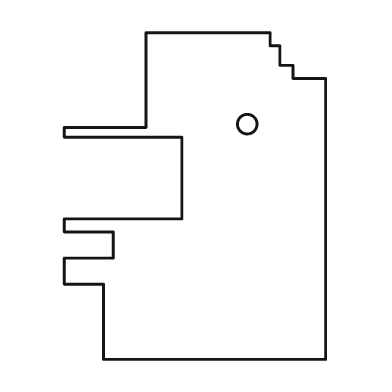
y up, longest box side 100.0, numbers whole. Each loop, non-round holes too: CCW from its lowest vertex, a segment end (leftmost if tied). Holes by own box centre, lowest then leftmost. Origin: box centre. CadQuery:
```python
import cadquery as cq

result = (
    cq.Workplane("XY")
    .moveTo(-28.0, -50.0)
    .lineTo(40.0, -50.0)
    .lineTo(40.0, 36.0)
    .lineTo(30.0, 36.0)
    .lineTo(30.0, 40.0)
    .lineTo(26.0, 40.0)
    .lineTo(26.0, 46.0)
    .lineTo(23.0, 46.0)
    .lineTo(23.0, 50.0)
    .lineTo(-15.0, 50.0)
    .lineTo(-15.0, 21.0)
    .lineTo(-40.0, 21.0)
    .lineTo(-40.0, 18.0)
    .lineTo(-4.0, 18.0)
    .lineTo(-4.0, -7.0)
    .lineTo(-40.0, -7.0)
    .lineTo(-40.0, -11.0)
    .lineTo(-25.0, -11.0)
    .lineTo(-25.0, -19.0)
    .lineTo(-40.0, -19.0)
    .lineTo(-40.0, -27.0)
    .lineTo(-28.0, -27.0)
    .close()
    .moveTo(16.0, 22.0)
    .circle(3.0)
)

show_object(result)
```